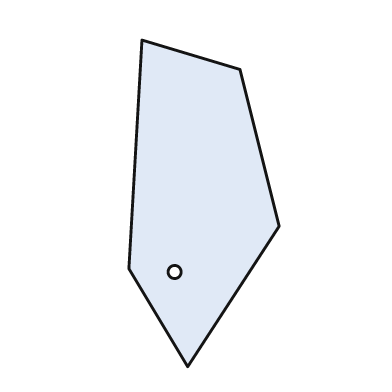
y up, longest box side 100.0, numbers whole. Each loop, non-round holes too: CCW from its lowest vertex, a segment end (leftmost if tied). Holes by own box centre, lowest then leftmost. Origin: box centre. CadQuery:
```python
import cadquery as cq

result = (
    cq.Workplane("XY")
    .moveTo(-5.0, -50.0)
    .lineTo(23.0, -7.0)
    .lineTo(11.0, 41.0)
    .lineTo(-19.0, 50.0)
    .lineTo(-23.0, -20.0)
    .close()
    .moveTo(-9.0, -21.0)
    .circle(2.0)
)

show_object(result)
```